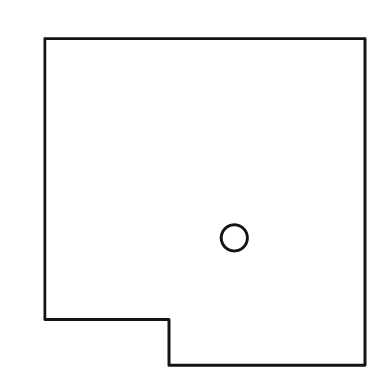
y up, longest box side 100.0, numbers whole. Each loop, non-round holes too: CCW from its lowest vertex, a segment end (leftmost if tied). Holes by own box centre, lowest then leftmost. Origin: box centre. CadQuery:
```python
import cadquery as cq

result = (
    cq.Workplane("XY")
    .moveTo(-11.0, -50.0)
    .lineTo(49.0, -50.0)
    .lineTo(49.0, 50.0)
    .lineTo(-49.0, 50.0)
    .lineTo(-49.0, -36.0)
    .lineTo(-11.0, -36.0)
    .close()
    .moveTo(9.0, -11.0)
    .circle(4.0)
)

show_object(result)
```